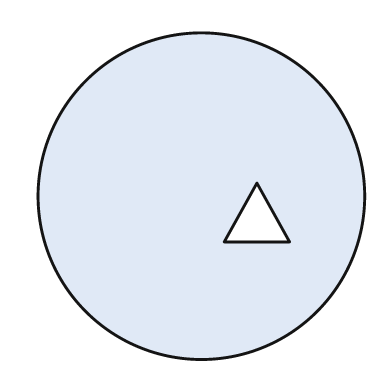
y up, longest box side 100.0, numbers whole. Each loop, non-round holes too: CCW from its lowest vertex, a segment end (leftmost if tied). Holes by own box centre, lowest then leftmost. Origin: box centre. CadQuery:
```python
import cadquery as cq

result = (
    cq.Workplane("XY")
    .moveTo(0.0, 0.0)
    .circle(50.0)
    .moveTo(7.0, -14.0)
    .lineTo(27.0, -14.0)
    .lineTo(17.0, 4.0)
    .close()
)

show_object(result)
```